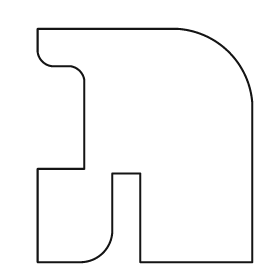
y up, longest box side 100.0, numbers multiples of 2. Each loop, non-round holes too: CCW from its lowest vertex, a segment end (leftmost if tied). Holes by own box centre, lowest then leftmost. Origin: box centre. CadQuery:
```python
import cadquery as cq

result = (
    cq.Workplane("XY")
    .moveTo(-46.0, -50.0)
    .lineTo(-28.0, -50.0)
    .threePointArc((-18.0, -46.0), (-14.0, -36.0))
    .lineTo(-14.0, -12.0)
    .lineTo(-2.0, -12.0)
    .lineTo(-2.0, -50.0)
    .lineTo(46.0, -50.0)
    .lineTo(46.0, 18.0)
    .threePointArc((36.0, 40.0), (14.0, 50.0))
    .lineTo(-46.0, 50.0)
    .lineTo(-46.0, 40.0)
    .threePointArc((-44.0, 36.0), (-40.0, 34.0))
    .lineTo(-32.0, 34.0)
    .threePointArc((-28.0, 32.0), (-26.0, 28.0))
    .lineTo(-26.0, -10.0)
    .lineTo(-46.0, -10.0)
    .close()
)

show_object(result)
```